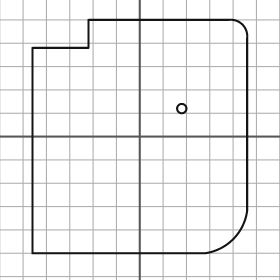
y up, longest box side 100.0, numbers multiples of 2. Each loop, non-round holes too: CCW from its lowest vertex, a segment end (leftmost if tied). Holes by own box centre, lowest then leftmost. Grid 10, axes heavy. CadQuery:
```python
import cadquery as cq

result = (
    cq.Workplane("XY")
    .moveTo(-46.0, -50.0)
    .lineTo(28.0, -50.0)
    .threePointArc((40.0, -44.0), (46.0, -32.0))
    .lineTo(46.0, 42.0)
    .threePointArc((44.0, 48.0), (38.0, 50.0))
    .lineTo(-22.0, 50.0)
    .lineTo(-22.0, 38.0)
    .lineTo(-46.0, 38.0)
    .close()
    .moveTo(18.0, 12.0)
    .circle(2.0)
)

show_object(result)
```